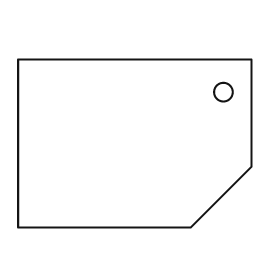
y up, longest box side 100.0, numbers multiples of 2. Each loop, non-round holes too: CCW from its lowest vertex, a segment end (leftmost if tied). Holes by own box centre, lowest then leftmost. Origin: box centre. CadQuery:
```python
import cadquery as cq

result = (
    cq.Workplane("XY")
    .moveTo(-50.0, -36.0)
    .lineTo(24.0, -36.0)
    .lineTo(50.0, -10.0)
    .lineTo(50.0, 36.0)
    .lineTo(-50.0, 36.0)
    .close()
    .moveTo(38.0, 22.0)
    .circle(4.0)
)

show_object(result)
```